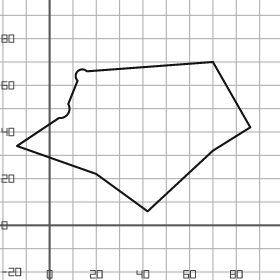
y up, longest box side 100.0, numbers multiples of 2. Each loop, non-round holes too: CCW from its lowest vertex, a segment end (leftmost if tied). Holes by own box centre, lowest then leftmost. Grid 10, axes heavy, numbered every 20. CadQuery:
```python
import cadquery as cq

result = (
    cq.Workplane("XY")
    .moveTo(42.0, 6.0)
    .lineTo(70.0, 32.0)
    .lineTo(86.0, 42.0)
    .lineTo(70.0, 70.0)
    .lineTo(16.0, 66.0)
    .threePointArc((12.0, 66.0), (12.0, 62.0))
    .lineTo(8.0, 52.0)
    .threePointArc((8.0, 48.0), (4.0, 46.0))
    .lineTo(-14.0, 34.0)
    .lineTo(20.0, 22.0)
    .close()
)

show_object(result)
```